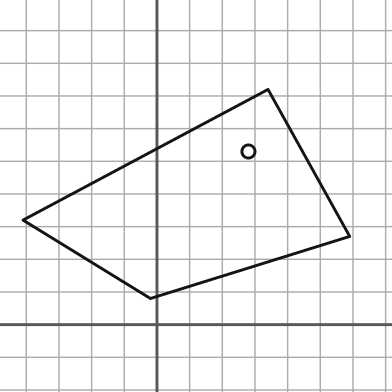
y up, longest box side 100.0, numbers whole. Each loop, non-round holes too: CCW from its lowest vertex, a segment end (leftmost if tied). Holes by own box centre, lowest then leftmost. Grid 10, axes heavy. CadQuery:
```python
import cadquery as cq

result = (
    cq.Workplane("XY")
    .moveTo(-2.0, 8.0)
    .lineTo(59.0, 27.0)
    .lineTo(34.0, 72.0)
    .lineTo(-41.0, 32.0)
    .close()
    .moveTo(28.0, 53.0)
    .circle(2.0)
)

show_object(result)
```